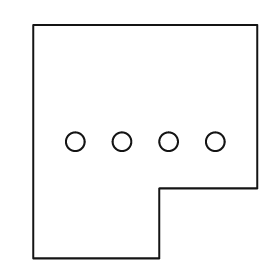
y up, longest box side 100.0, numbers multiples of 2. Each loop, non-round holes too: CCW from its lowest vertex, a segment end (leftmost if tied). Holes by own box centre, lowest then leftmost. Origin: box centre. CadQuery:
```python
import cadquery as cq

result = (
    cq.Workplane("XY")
    .moveTo(-48.0, -50.0)
    .lineTo(6.0, -50.0)
    .lineTo(6.0, -20.0)
    .lineTo(48.0, -20.0)
    .lineTo(48.0, 50.0)
    .lineTo(-48.0, 50.0)
    .close()
    .moveTo(-30.0, 0.0)
    .circle(4.0)
    .moveTo(-10.0, 0.0)
    .circle(4.0)
    .moveTo(10.0, 0.0)
    .circle(4.0)
    .moveTo(30.0, 0.0)
    .circle(4.0)
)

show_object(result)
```